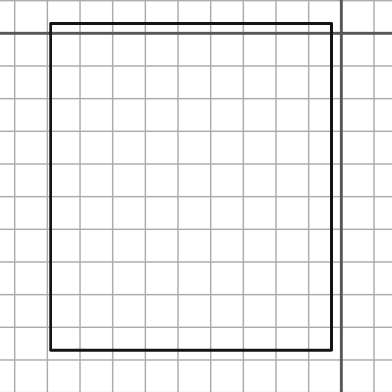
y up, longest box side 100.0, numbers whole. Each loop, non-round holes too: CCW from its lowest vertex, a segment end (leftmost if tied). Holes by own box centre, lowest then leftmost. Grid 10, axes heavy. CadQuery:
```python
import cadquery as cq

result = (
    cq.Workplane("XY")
    .moveTo(-89.0, -97.0)
    .lineTo(-3.0, -97.0)
    .lineTo(-3.0, 3.0)
    .lineTo(-89.0, 3.0)
    .close()
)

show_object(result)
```